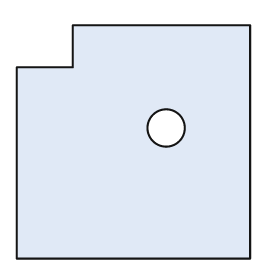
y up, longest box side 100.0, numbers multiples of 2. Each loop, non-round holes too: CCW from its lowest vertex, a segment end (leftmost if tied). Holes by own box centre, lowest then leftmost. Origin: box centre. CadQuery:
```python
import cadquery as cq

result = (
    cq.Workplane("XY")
    .moveTo(-50.0, -50.0)
    .lineTo(50.0, -50.0)
    .lineTo(50.0, 50.0)
    .lineTo(-26.0, 50.0)
    .lineTo(-26.0, 32.0)
    .lineTo(-50.0, 32.0)
    .close()
    .moveTo(14.0, 6.0)
    .circle(8.0)
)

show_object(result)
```